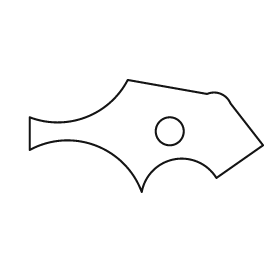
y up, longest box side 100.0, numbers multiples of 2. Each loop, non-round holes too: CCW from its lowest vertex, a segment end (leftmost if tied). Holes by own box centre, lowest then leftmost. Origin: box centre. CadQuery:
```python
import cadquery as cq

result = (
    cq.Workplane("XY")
    .moveTo(-2.0, -24.0)
    .threePointArc((12.0, -10.0), (30.0, -18.0))
    .lineTo(50.0, -4.0)
    .lineTo(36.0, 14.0)
    .threePointArc((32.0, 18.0), (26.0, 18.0))
    .lineTo(-8.0, 24.0)
    .threePointArc((-26.0, 8.0), (-50.0, 8.0))
    .lineTo(-50.0, -6.0)
    .threePointArc((-22.0, -4.0), (-2.0, -24.0))
    .close()
    .moveTo(10.0, 2.0)
    .circle(6.0)
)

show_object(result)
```